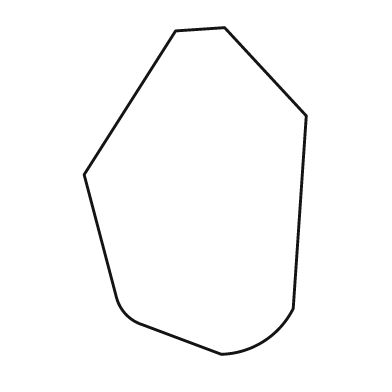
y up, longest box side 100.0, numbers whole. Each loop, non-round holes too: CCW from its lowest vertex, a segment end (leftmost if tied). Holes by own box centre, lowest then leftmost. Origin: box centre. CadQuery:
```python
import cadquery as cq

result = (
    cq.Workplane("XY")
    .moveTo(8.0, -50.0)
    .threePointArc((21.0, -46.0), (30.0, -36.0))
    .lineTo(34.0, 23.0)
    .lineTo(9.0, 50.0)
    .lineTo(-6.0, 49.0)
    .lineTo(-34.0, 5.0)
    .lineTo(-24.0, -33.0)
    .threePointArc((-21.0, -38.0), (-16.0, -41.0))
    .close()
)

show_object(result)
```